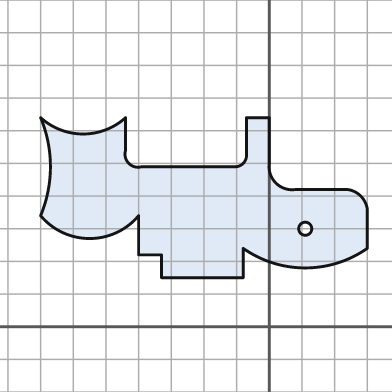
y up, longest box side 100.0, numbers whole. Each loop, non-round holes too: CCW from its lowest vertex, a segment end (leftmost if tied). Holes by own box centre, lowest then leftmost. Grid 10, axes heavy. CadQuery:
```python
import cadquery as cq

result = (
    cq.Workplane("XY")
    .moveTo(-33.0, 15.0)
    .lineTo(-8.0, 15.0)
    .lineTo(-8.0, 24.0)
    .threePointArc((11.0, 18.0), (30.0, 24.0))
    .lineTo(30.0, 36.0)
    .threePointArc((28.0, 40.0), (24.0, 42.0))
    .lineTo(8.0, 42.0)
    .threePointArc((2.0, 44.0), (0.0, 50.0))
    .lineTo(0.0, 64.0)
    .lineTo(-7.0, 64.0)
    .lineTo(-7.0, 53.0)
    .threePointArc((-8.0, 50.0), (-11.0, 49.0))
    .lineTo(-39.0, 49.0)
    .threePointArc((-43.0, 50.0), (-44.0, 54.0))
    .lineTo(-44.0, 64.0)
    .threePointArc((-57.0, 59.0), (-70.0, 64.0))
    .threePointArc((-67.0, 49.0), (-70.0, 34.0))
    .threePointArc((-55.0, 27.0), (-40.0, 34.0))
    .lineTo(-40.0, 22.0)
    .lineTo(-33.0, 22.0)
    .close()
    .moveTo(11.0, 30.0)
    .circle(2.0)
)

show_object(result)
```